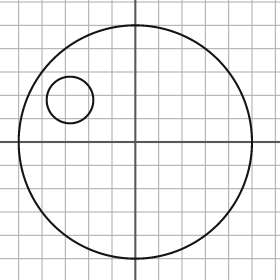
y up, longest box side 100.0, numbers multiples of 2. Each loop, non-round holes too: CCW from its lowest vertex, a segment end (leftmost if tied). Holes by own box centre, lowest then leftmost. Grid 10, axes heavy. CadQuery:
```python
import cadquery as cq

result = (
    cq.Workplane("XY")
    .moveTo(0.0, 0.0)
    .circle(50.0)
    .moveTo(-28.0, 18.0)
    .circle(10.0)
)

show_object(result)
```